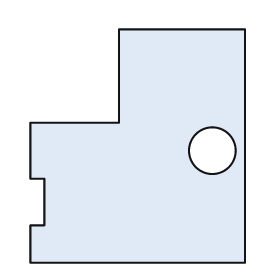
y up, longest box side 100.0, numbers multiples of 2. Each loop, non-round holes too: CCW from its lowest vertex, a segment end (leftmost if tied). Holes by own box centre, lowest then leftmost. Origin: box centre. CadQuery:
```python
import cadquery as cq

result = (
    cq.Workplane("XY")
    .moveTo(-46.0, -50.0)
    .lineTo(46.0, -50.0)
    .lineTo(46.0, 50.0)
    .lineTo(-8.0, 50.0)
    .lineTo(-8.0, 10.0)
    .lineTo(-46.0, 10.0)
    .lineTo(-46.0, -14.0)
    .lineTo(-40.0, -14.0)
    .lineTo(-40.0, -34.0)
    .lineTo(-46.0, -34.0)
    .close()
    .moveTo(32.0, -2.0)
    .circle(10.0)
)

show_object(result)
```